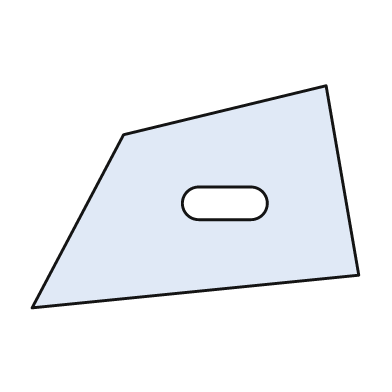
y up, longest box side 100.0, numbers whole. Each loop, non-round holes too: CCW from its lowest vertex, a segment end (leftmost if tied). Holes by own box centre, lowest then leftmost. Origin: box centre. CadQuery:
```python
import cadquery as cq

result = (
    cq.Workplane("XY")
    .moveTo(-50.0, -34.0)
    .lineTo(50.0, -24.0)
    .lineTo(40.0, 34.0)
    .lineTo(-22.0, 19.0)
    .close()
    .moveTo(1.0, -7.0)
    .lineTo(17.0, -7.0)
    .threePointArc((22.0, -2.0), (17.0, 3.0))
    .lineTo(1.0, 3.0)
    .threePointArc((-4.0, -2.0), (1.0, -7.0))
    .close()
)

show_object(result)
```